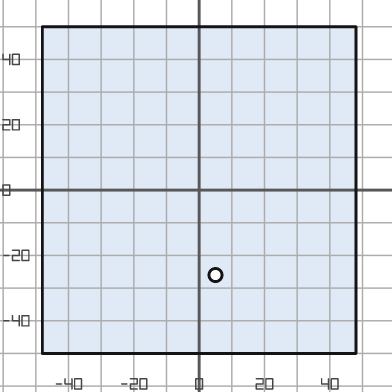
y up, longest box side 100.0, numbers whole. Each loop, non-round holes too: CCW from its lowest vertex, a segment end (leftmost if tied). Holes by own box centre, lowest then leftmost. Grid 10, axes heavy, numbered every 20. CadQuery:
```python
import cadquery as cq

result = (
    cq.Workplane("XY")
    .moveTo(-48.0, -50.0)
    .lineTo(48.0, -50.0)
    .lineTo(48.0, 50.0)
    .lineTo(-48.0, 50.0)
    .close()
    .moveTo(5.0, -26.0)
    .circle(2.0)
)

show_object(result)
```